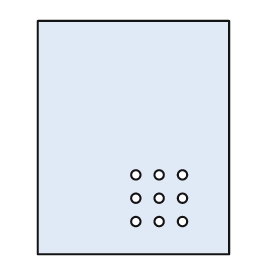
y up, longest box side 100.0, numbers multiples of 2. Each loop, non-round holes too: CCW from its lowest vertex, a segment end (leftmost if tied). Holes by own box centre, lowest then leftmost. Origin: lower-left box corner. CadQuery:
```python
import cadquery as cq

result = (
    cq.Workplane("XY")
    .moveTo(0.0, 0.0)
    .lineTo(82.0, 0.0)
    .lineTo(82.0, 100.0)
    .lineTo(0.0, 100.0)
    .close()
    .moveTo(42.0, 14.0)
    .circle(2.0)
    .moveTo(52.0, 14.0)
    .circle(2.0)
    .moveTo(62.0, 14.0)
    .circle(2.0)
    .moveTo(42.0, 24.0)
    .circle(2.0)
    .moveTo(52.0, 24.0)
    .circle(2.0)
    .moveTo(62.0, 24.0)
    .circle(2.0)
    .moveTo(42.0, 34.0)
    .circle(2.0)
    .moveTo(52.0, 34.0)
    .circle(2.0)
    .moveTo(62.0, 34.0)
    .circle(2.0)
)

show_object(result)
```